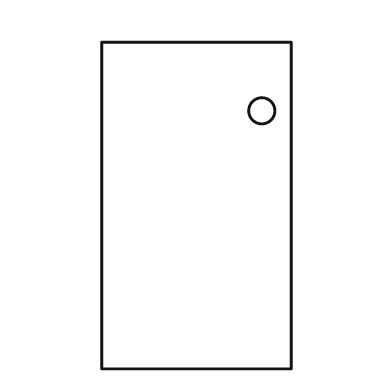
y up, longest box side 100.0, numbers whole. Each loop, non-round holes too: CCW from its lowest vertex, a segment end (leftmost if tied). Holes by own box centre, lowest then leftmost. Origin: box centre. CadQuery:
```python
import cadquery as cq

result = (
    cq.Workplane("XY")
    .moveTo(-29.0, -50.0)
    .lineTo(29.0, -50.0)
    .lineTo(29.0, 50.0)
    .lineTo(-29.0, 50.0)
    .close()
    .moveTo(20.0, 29.0)
    .circle(4.0)
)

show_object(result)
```